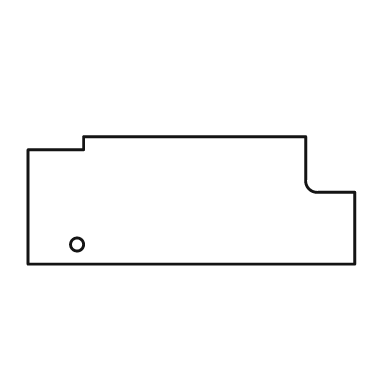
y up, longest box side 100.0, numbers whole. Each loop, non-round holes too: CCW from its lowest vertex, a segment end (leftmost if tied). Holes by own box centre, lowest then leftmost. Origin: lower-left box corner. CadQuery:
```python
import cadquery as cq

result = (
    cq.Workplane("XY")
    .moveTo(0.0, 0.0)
    .lineTo(100.0, 0.0)
    .lineTo(100.0, 22.0)
    .lineTo(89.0, 22.0)
    .threePointArc((86.0, 23.0), (85.0, 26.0))
    .lineTo(85.0, 39.0)
    .lineTo(17.0, 39.0)
    .lineTo(17.0, 35.0)
    .lineTo(0.0, 35.0)
    .close()
    .moveTo(15.0, 6.0)
    .circle(2.0)
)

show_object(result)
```